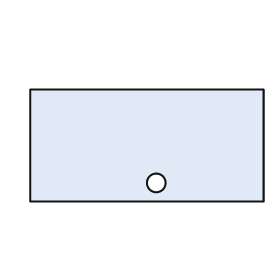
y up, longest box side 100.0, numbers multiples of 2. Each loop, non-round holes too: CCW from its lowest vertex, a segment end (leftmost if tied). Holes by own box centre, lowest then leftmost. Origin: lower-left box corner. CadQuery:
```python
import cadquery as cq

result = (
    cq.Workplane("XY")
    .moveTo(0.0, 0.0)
    .lineTo(100.0, 0.0)
    .lineTo(100.0, 48.0)
    .lineTo(0.0, 48.0)
    .close()
    .moveTo(54.0, 8.0)
    .circle(4.0)
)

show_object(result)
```